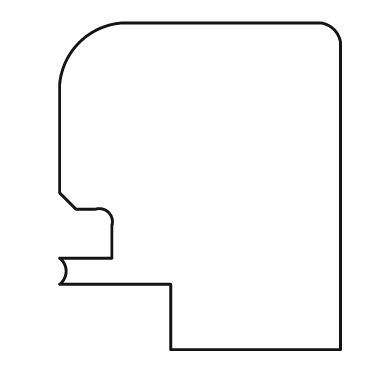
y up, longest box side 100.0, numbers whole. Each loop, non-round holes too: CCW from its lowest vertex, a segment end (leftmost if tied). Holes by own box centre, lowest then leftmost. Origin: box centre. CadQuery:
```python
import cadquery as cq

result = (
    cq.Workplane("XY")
    .moveTo(-9.0, -50.0)
    .lineTo(43.0, -50.0)
    .lineTo(43.0, 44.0)
    .threePointArc((41.0, 48.0), (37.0, 50.0))
    .lineTo(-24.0, 50.0)
    .threePointArc((-37.0, 44.0), (-43.0, 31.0))
    .lineTo(-43.0, -2.0)
    .lineTo(-38.0, -7.0)
    .lineTo(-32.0, -7.0)
    .threePointArc((-28.0, -8.0), (-27.0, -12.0))
    .lineTo(-27.0, -22.0)
    .lineTo(-43.0, -22.0)
    .threePointArc((-41.0, -26.0), (-43.0, -30.0))
    .lineTo(-9.0, -30.0)
    .close()
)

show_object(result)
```